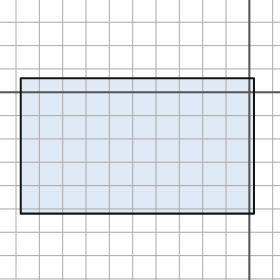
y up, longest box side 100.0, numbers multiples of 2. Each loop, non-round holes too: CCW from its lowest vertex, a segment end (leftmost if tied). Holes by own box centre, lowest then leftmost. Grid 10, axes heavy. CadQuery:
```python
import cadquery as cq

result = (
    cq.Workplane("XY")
    .moveTo(-98.0, -52.0)
    .lineTo(2.0, -52.0)
    .lineTo(2.0, 6.0)
    .lineTo(-98.0, 6.0)
    .close()
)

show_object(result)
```